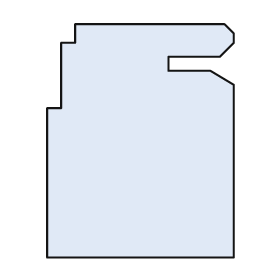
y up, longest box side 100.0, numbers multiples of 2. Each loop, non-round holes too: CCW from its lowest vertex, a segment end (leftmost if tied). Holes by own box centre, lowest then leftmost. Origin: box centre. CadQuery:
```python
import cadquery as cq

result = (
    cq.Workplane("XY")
    .moveTo(-40.0, -50.0)
    .lineTo(40.0, -50.0)
    .lineTo(40.0, 24.0)
    .lineTo(30.0, 30.0)
    .lineTo(12.0, 30.0)
    .lineTo(12.0, 36.0)
    .lineTo(34.0, 36.0)
    .lineTo(40.0, 42.0)
    .lineTo(40.0, 46.0)
    .lineTo(36.0, 50.0)
    .lineTo(-28.0, 50.0)
    .lineTo(-28.0, 42.0)
    .lineTo(-34.0, 42.0)
    .lineTo(-34.0, 14.0)
    .lineTo(-40.0, 14.0)
    .close()
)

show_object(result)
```